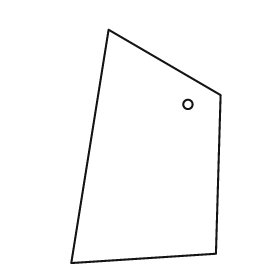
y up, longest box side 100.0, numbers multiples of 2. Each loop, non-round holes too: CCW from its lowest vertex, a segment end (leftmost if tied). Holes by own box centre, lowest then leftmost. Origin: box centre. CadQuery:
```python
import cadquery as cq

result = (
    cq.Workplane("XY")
    .moveTo(-32.0, -50.0)
    .lineTo(30.0, -46.0)
    .lineTo(32.0, 22.0)
    .lineTo(-16.0, 50.0)
    .close()
    .moveTo(18.0, 18.0)
    .circle(2.0)
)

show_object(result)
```